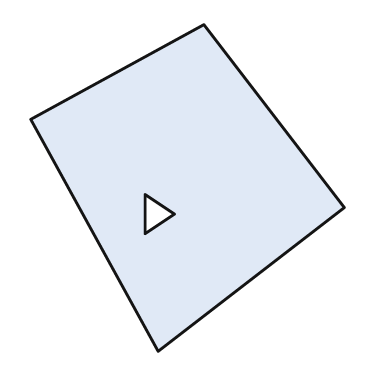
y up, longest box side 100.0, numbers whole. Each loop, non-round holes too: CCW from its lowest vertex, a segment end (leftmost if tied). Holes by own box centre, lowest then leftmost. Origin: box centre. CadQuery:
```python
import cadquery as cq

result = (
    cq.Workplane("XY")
    .moveTo(-9.0, -50.0)
    .lineTo(48.0, -6.0)
    .lineTo(5.0, 50.0)
    .lineTo(-48.0, 21.0)
    .close()
    .moveTo(-13.0, -14.0)
    .lineTo(-4.0, -8.0)
    .lineTo(-13.0, -2.0)
    .close()
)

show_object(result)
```